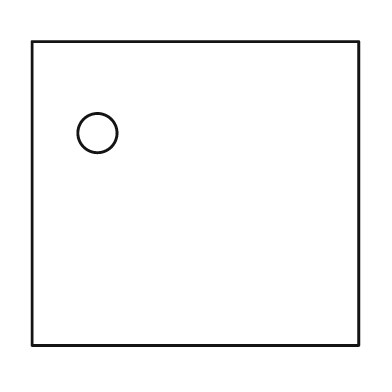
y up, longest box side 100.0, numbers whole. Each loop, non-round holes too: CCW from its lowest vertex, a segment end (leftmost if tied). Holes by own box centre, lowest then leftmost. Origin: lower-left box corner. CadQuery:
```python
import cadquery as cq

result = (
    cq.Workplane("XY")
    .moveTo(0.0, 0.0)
    .lineTo(100.0, 0.0)
    .lineTo(100.0, 93.0)
    .lineTo(0.0, 93.0)
    .close()
    .moveTo(20.0, 65.0)
    .circle(6.0)
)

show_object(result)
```